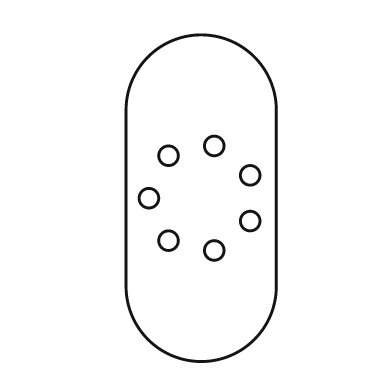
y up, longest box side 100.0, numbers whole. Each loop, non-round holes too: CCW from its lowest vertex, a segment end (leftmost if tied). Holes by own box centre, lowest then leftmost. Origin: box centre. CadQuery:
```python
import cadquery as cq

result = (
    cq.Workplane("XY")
    .moveTo(-23.0, -27.0)
    .threePointArc((0.0, -50.0), (23.0, -27.0))
    .lineTo(23.0, 27.0)
    .threePointArc((0.0, 50.0), (-23.0, 27.0))
    .close()
    .moveTo(4.0, -16.0)
    .circle(3.0)
    .moveTo(-10.0, -13.0)
    .circle(3.0)
    .moveTo(15.0, -7.0)
    .circle(3.0)
    .moveTo(-16.0, 0.0)
    .circle(3.0)
    .moveTo(15.0, 7.0)
    .circle(3.0)
    .moveTo(-10.0, 13.0)
    .circle(3.0)
    .moveTo(4.0, 16.0)
    .circle(3.0)
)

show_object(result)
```